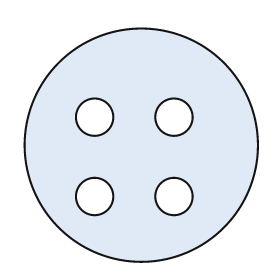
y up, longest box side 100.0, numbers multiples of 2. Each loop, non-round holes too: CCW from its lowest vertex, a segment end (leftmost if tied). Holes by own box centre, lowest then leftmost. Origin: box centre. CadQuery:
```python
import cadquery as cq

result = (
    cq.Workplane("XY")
    .moveTo(0.0, 0.0)
    .circle(50.0)
    .moveTo(-20.0, -22.0)
    .circle(8.0)
    .moveTo(14.0, -22.0)
    .circle(8.0)
    .moveTo(-20.0, 12.0)
    .circle(8.0)
    .moveTo(14.0, 12.0)
    .circle(8.0)
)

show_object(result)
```